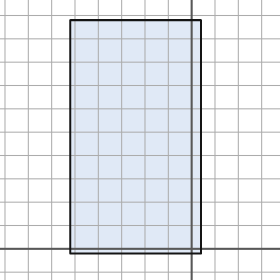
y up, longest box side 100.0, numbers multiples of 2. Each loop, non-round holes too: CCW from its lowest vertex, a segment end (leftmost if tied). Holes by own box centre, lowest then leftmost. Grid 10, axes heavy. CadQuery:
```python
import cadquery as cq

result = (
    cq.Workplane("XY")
    .moveTo(-52.0, -2.0)
    .lineTo(4.0, -2.0)
    .lineTo(4.0, 98.0)
    .lineTo(-52.0, 98.0)
    .close()
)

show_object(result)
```